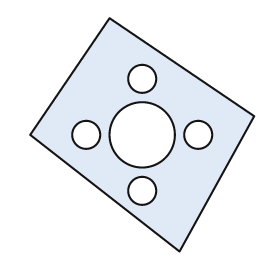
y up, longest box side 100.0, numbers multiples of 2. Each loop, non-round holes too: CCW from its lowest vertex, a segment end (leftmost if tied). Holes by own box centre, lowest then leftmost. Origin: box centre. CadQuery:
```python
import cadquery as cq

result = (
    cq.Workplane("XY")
    .moveTo(16.0, -50.0)
    .lineTo(48.0, 8.0)
    .lineTo(-14.0, 50.0)
    .lineTo(-48.0, 0.0)
    .close()
    .moveTo(0.0, -24.0)
    .circle(6.0)
    .moveTo(-24.0, 0.0)
    .circle(6.0)
    .moveTo(0.0, 0.0)
    .circle(14.0)
    .moveTo(24.0, 0.0)
    .circle(6.0)
    .moveTo(0.0, 24.0)
    .circle(6.0)
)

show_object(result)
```